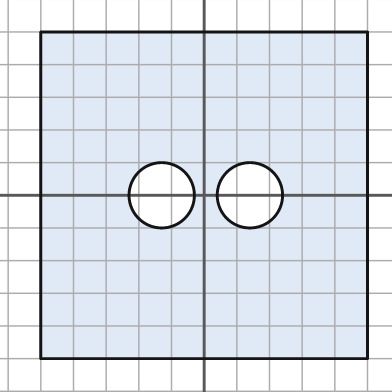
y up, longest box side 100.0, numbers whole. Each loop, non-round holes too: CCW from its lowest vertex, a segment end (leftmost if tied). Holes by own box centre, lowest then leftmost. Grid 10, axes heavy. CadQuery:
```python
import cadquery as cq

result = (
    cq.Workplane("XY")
    .moveTo(-50.0, -50.0)
    .lineTo(50.0, -50.0)
    .lineTo(50.0, 50.0)
    .lineTo(-50.0, 50.0)
    .close()
    .moveTo(-13.0, 0.0)
    .circle(10.0)
    .moveTo(14.0, 0.0)
    .circle(10.0)
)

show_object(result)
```